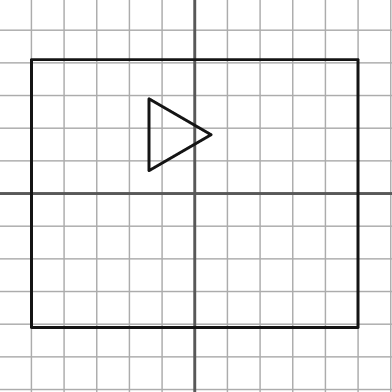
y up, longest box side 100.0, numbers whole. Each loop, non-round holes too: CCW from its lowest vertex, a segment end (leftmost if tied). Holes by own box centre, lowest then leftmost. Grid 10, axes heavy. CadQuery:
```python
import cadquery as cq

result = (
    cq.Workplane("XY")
    .moveTo(-50.0, -41.0)
    .lineTo(50.0, -41.0)
    .lineTo(50.0, 41.0)
    .lineTo(-50.0, 41.0)
    .close()
    .moveTo(-14.0, 7.0)
    .lineTo(5.0, 18.0)
    .lineTo(-14.0, 29.0)
    .close()
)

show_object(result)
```